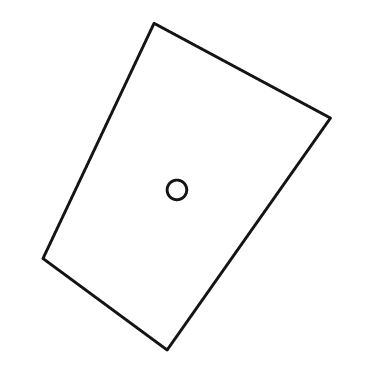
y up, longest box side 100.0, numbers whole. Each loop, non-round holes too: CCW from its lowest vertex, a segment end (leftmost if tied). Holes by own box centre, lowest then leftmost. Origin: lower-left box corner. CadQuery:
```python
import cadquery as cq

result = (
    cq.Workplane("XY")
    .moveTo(38.0, 0.0)
    .lineTo(88.0, 71.0)
    .lineTo(34.0, 100.0)
    .lineTo(0.0, 28.0)
    .close()
    .moveTo(41.0, 49.0)
    .circle(3.0)
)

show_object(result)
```